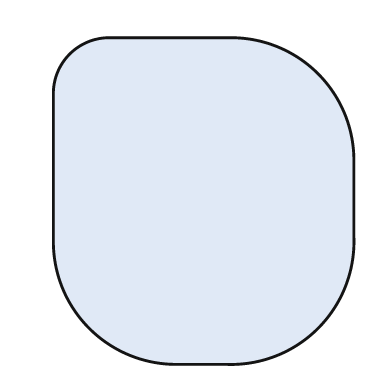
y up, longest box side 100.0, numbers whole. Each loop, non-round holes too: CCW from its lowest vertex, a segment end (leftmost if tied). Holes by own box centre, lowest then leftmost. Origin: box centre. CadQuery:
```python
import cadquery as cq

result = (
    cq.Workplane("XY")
    .moveTo(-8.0, -50.0)
    .lineTo(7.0, -50.0)
    .threePointArc((35.0, -39.0), (46.0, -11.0))
    .lineTo(46.0, 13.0)
    .threePointArc((35.0, 39.0), (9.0, 50.0))
    .lineTo(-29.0, 50.0)
    .threePointArc((-41.0, 45.0), (-46.0, 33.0))
    .lineTo(-46.0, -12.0)
    .threePointArc((-35.0, -39.0), (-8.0, -50.0))
    .close()
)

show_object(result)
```